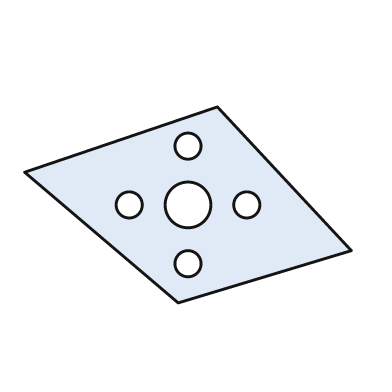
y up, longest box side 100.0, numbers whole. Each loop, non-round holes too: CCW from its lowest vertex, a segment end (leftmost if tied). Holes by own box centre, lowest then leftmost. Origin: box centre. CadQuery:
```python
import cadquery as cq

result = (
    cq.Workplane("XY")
    .moveTo(-3.0, -30.0)
    .lineTo(50.0, -14.0)
    .lineTo(9.0, 30.0)
    .lineTo(-50.0, 10.0)
    .close()
    .moveTo(0.0, -18.0)
    .circle(4.0)
    .moveTo(-18.0, 0.0)
    .circle(4.0)
    .moveTo(0.0, 0.0)
    .circle(7.0)
    .moveTo(18.0, 0.0)
    .circle(4.0)
    .moveTo(0.0, 18.0)
    .circle(4.0)
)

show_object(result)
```